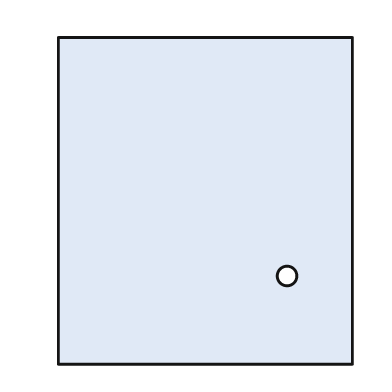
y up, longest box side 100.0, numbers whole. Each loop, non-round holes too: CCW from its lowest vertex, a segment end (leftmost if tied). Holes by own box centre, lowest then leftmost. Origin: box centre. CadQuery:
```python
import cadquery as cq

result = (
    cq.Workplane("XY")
    .moveTo(-45.0, -50.0)
    .lineTo(45.0, -50.0)
    .lineTo(45.0, 50.0)
    .lineTo(-45.0, 50.0)
    .close()
    .moveTo(25.0, -23.0)
    .circle(3.0)
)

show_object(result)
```